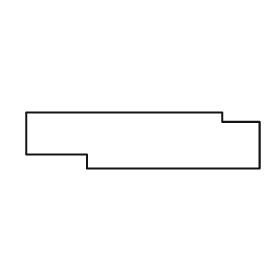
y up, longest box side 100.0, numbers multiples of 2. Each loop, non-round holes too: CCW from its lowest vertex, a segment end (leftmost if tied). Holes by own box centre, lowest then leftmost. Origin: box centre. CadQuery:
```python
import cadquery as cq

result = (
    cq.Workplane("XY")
    .moveTo(-24.0, -12.0)
    .lineTo(50.0, -12.0)
    .lineTo(50.0, 8.0)
    .lineTo(34.0, 8.0)
    .lineTo(34.0, 12.0)
    .lineTo(-50.0, 12.0)
    .lineTo(-50.0, -6.0)
    .lineTo(-24.0, -6.0)
    .close()
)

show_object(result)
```